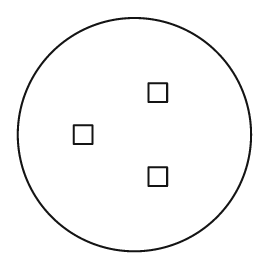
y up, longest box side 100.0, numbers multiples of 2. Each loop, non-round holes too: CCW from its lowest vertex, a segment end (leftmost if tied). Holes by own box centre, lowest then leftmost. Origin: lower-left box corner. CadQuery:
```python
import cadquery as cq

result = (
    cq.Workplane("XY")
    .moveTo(50.0, 50.0)
    .circle(50.0)
    .moveTo(56.0, 28.0)
    .lineTo(64.0, 28.0)
    .lineTo(64.0, 36.0)
    .lineTo(56.0, 36.0)
    .close()
    .moveTo(24.0, 46.0)
    .lineTo(32.0, 46.0)
    .lineTo(32.0, 54.0)
    .lineTo(24.0, 54.0)
    .close()
    .moveTo(56.0, 64.0)
    .lineTo(64.0, 64.0)
    .lineTo(64.0, 72.0)
    .lineTo(56.0, 72.0)
    .close()
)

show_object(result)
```